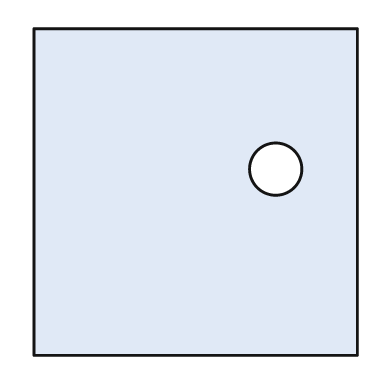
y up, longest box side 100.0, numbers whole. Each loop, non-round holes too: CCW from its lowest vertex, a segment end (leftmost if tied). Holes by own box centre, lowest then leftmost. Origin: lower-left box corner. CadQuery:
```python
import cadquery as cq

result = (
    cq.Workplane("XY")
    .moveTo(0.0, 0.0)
    .lineTo(99.0, 0.0)
    .lineTo(99.0, 100.0)
    .lineTo(0.0, 100.0)
    .close()
    .moveTo(74.0, 57.0)
    .circle(8.0)
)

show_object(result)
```